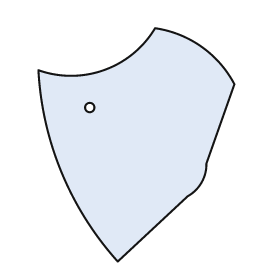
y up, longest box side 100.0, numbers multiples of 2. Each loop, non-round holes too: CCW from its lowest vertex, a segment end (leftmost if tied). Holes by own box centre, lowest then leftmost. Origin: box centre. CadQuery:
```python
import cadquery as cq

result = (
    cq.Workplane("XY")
    .moveTo(-8.0, -50.0)
    .lineTo(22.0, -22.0)
    .threePointArc((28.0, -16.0), (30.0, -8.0))
    .lineTo(42.0, 26.0)
    .threePointArc((28.0, 42.0), (8.0, 50.0))
    .threePointArc((-14.0, 32.0), (-42.0, 32.0))
    .threePointArc((-32.0, -12.0), (-8.0, -50.0))
    .close()
    .moveTo(-20.0, 16.0)
    .circle(2.0)
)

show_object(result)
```